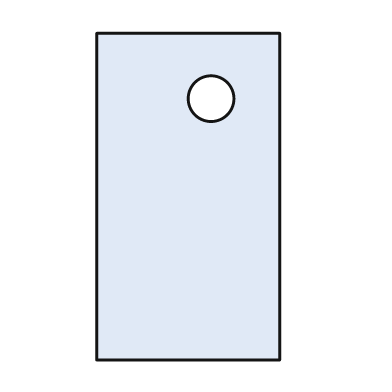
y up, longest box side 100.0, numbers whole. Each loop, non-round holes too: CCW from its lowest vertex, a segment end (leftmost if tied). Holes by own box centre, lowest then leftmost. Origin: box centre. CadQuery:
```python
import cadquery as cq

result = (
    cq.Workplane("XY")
    .moveTo(-28.0, -50.0)
    .lineTo(28.0, -50.0)
    .lineTo(28.0, 50.0)
    .lineTo(-28.0, 50.0)
    .close()
    .moveTo(7.0, 30.0)
    .circle(7.0)
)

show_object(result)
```